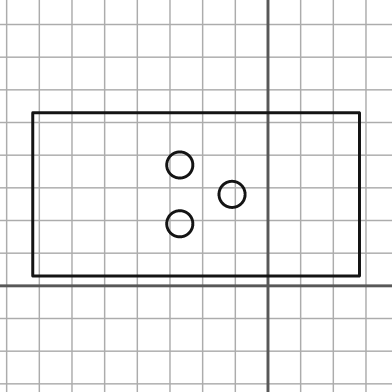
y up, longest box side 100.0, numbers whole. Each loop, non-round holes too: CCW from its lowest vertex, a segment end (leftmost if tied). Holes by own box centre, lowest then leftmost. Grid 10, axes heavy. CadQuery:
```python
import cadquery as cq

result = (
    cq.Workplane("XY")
    .moveTo(-72.0, 3.0)
    .lineTo(28.0, 3.0)
    .lineTo(28.0, 53.0)
    .lineTo(-72.0, 53.0)
    .close()
    .moveTo(-27.0, 19.0)
    .circle(4.0)
    .moveTo(-11.0, 28.0)
    .circle(4.0)
    .moveTo(-27.0, 37.0)
    .circle(4.0)
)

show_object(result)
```